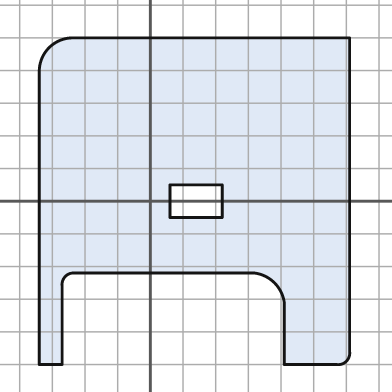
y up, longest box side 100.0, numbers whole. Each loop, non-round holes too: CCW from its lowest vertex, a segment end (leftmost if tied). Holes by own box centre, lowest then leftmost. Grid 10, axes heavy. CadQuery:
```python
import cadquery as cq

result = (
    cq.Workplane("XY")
    .moveTo(-34.0, -50.0)
    .lineTo(-27.0, -50.0)
    .lineTo(-27.0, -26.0)
    .threePointArc((-26.0, -23.0), (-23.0, -22.0))
    .lineTo(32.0, -22.0)
    .threePointArc((38.0, -25.0), (41.0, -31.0))
    .lineTo(41.0, -50.0)
    .lineTo(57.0, -50.0)
    .threePointArc((60.0, -49.0), (61.0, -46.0))
    .lineTo(61.0, 50.0)
    .lineTo(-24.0, 50.0)
    .threePointArc((-31.0, 47.0), (-34.0, 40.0))
    .close()
    .moveTo(6.0, -5.0)
    .lineTo(22.0, -5.0)
    .lineTo(22.0, 5.0)
    .lineTo(6.0, 5.0)
    .close()
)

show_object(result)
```